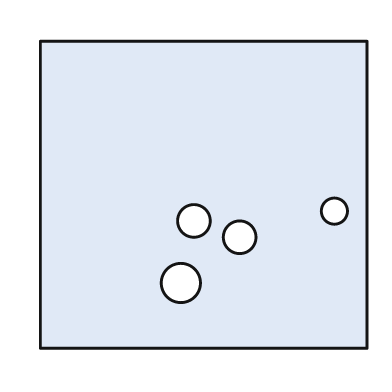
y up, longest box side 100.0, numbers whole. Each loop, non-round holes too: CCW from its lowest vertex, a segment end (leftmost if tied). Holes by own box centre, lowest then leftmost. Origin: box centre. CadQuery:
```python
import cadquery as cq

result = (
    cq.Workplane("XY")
    .moveTo(-50.0, -47.0)
    .lineTo(50.0, -47.0)
    .lineTo(50.0, 47.0)
    .lineTo(-50.0, 47.0)
    .close()
    .moveTo(-7.0, -27.0)
    .circle(6.0)
    .moveTo(11.0, -13.0)
    .circle(5.0)
    .moveTo(-3.0, -8.0)
    .circle(5.0)
    .moveTo(40.0, -5.0)
    .circle(4.0)
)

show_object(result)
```